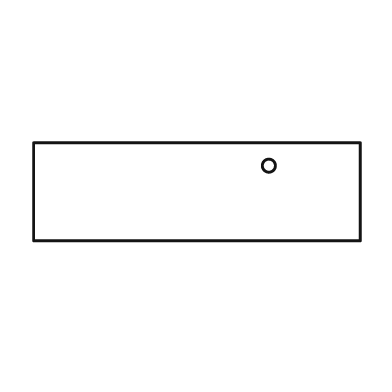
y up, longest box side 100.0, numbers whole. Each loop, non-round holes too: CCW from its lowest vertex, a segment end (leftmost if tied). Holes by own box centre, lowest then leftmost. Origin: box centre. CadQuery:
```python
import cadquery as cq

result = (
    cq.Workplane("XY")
    .moveTo(-50.0, -15.0)
    .lineTo(50.0, -15.0)
    .lineTo(50.0, 15.0)
    .lineTo(-50.0, 15.0)
    .close()
    .moveTo(22.0, 8.0)
    .circle(2.0)
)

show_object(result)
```